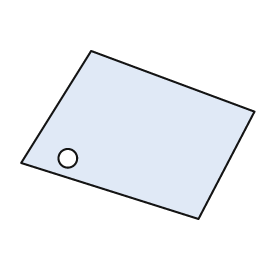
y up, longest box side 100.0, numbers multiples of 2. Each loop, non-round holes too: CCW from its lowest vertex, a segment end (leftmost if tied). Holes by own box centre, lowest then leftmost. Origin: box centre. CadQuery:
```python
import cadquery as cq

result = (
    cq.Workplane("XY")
    .moveTo(26.0, -36.0)
    .lineTo(50.0, 10.0)
    .lineTo(-20.0, 36.0)
    .lineTo(-50.0, -12.0)
    .close()
    .moveTo(-30.0, -10.0)
    .circle(4.0)
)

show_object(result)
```